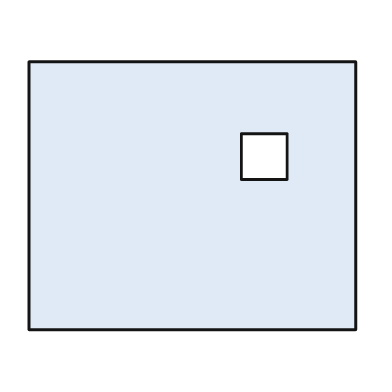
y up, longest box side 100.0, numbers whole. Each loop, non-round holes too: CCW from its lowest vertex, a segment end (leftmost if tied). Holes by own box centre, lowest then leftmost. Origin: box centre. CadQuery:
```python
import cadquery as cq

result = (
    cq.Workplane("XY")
    .moveTo(-50.0, -41.0)
    .lineTo(50.0, -41.0)
    .lineTo(50.0, 41.0)
    .lineTo(-50.0, 41.0)
    .close()
    .moveTo(15.0, 5.0)
    .lineTo(29.0, 5.0)
    .lineTo(29.0, 19.0)
    .lineTo(15.0, 19.0)
    .close()
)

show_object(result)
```